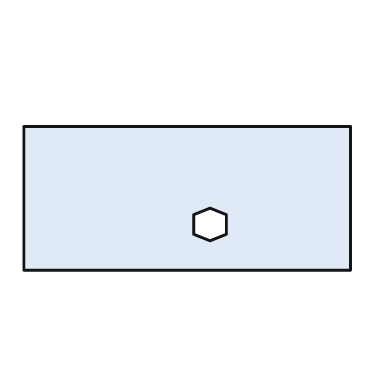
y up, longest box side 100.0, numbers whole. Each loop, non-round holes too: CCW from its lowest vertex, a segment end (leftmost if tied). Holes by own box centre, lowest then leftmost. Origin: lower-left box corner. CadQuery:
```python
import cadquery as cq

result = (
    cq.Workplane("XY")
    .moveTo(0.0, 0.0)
    .lineTo(100.0, 0.0)
    .lineTo(100.0, 44.0)
    .lineTo(0.0, 44.0)
    .close()
    .moveTo(57.0, 9.0)
    .lineTo(62.0, 11.0)
    .lineTo(62.0, 17.0)
    .lineTo(57.0, 19.0)
    .lineTo(52.0, 17.0)
    .lineTo(52.0, 11.0)
    .close()
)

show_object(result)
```